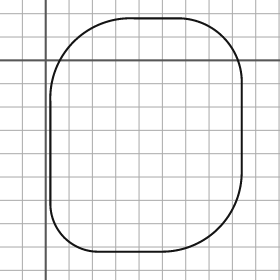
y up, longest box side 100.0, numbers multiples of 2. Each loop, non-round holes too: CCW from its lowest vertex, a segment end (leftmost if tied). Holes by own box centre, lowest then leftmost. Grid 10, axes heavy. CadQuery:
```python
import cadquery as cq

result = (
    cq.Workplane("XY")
    .moveTo(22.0, -82.0)
    .lineTo(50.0, -82.0)
    .threePointArc((74.0, -72.0), (84.0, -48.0))
    .lineTo(84.0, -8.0)
    .threePointArc((76.0, 10.0), (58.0, 18.0))
    .lineTo(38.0, 18.0)
    .threePointArc((12.0, 8.0), (2.0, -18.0))
    .lineTo(2.0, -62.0)
    .threePointArc((8.0, -76.0), (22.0, -82.0))
    .close()
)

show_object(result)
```